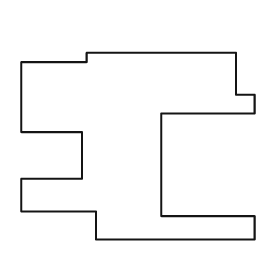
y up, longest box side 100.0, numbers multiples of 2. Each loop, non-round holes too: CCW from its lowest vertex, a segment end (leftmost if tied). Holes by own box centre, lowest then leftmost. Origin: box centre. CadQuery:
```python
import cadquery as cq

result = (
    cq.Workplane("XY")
    .moveTo(-18.0, -40.0)
    .lineTo(50.0, -40.0)
    .lineTo(50.0, -30.0)
    .lineTo(10.0, -30.0)
    .lineTo(10.0, 14.0)
    .lineTo(50.0, 14.0)
    .lineTo(50.0, 22.0)
    .lineTo(42.0, 22.0)
    .lineTo(42.0, 40.0)
    .lineTo(-22.0, 40.0)
    .lineTo(-22.0, 36.0)
    .lineTo(-50.0, 36.0)
    .lineTo(-50.0, 6.0)
    .lineTo(-24.0, 6.0)
    .lineTo(-24.0, -14.0)
    .lineTo(-50.0, -14.0)
    .lineTo(-50.0, -28.0)
    .lineTo(-18.0, -28.0)
    .close()
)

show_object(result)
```